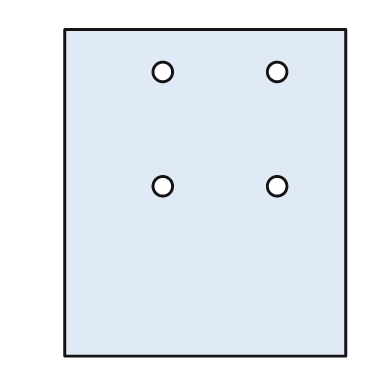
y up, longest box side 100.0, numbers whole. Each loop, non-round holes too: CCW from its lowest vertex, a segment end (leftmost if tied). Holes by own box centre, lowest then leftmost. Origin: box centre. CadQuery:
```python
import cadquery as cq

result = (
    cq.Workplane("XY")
    .moveTo(-43.0, -50.0)
    .lineTo(43.0, -50.0)
    .lineTo(43.0, 50.0)
    .lineTo(-43.0, 50.0)
    .close()
    .moveTo(-13.0, 2.0)
    .circle(3.0)
    .moveTo(22.0, 2.0)
    .circle(3.0)
    .moveTo(-13.0, 37.0)
    .circle(3.0)
    .moveTo(22.0, 37.0)
    .circle(3.0)
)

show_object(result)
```